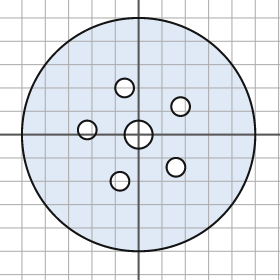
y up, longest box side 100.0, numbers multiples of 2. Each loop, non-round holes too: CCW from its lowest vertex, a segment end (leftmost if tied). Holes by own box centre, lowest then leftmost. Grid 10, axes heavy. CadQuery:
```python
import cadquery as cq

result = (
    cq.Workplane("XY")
    .moveTo(0.0, 0.0)
    .circle(50.0)
    .moveTo(-8.0, -20.0)
    .circle(4.0)
    .moveTo(16.0, -14.0)
    .circle(4.0)
    .moveTo(0.0, 0.0)
    .circle(6.0)
    .moveTo(-22.0, 2.0)
    .circle(4.0)
    .moveTo(18.0, 12.0)
    .circle(4.0)
    .moveTo(-6.0, 20.0)
    .circle(4.0)
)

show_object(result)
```